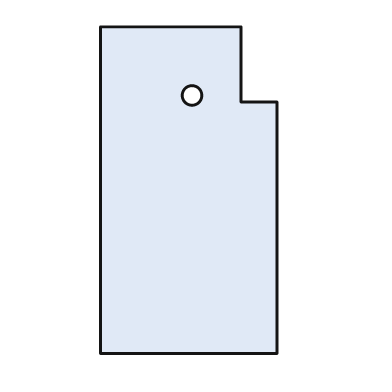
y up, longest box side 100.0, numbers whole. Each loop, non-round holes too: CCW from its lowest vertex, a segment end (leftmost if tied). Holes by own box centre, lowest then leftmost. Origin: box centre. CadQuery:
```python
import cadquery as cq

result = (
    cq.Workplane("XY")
    .moveTo(-27.0, -50.0)
    .lineTo(27.0, -50.0)
    .lineTo(27.0, 27.0)
    .lineTo(16.0, 27.0)
    .lineTo(16.0, 50.0)
    .lineTo(-27.0, 50.0)
    .close()
    .moveTo(1.0, 29.0)
    .circle(3.0)
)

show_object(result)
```